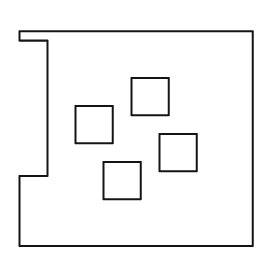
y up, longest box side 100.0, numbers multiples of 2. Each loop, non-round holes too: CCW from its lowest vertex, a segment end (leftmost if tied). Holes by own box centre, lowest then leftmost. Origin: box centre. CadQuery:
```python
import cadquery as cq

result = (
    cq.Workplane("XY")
    .moveTo(-50.0, -46.0)
    .lineTo(50.0, -46.0)
    .lineTo(50.0, 46.0)
    .lineTo(-50.0, 46.0)
    .lineTo(-50.0, 42.0)
    .lineTo(-38.0, 42.0)
    .lineTo(-38.0, -16.0)
    .lineTo(-50.0, -16.0)
    .close()
    .moveTo(-14.0, -26.0)
    .lineTo(2.0, -26.0)
    .lineTo(2.0, -10.0)
    .lineTo(-14.0, -10.0)
    .close()
    .moveTo(10.0, -14.0)
    .lineTo(26.0, -14.0)
    .lineTo(26.0, 2.0)
    .lineTo(10.0, 2.0)
    .close()
    .moveTo(-26.0, -2.0)
    .lineTo(-10.0, -2.0)
    .lineTo(-10.0, 14.0)
    .lineTo(-26.0, 14.0)
    .close()
    .moveTo(-2.0, 10.0)
    .lineTo(14.0, 10.0)
    .lineTo(14.0, 26.0)
    .lineTo(-2.0, 26.0)
    .close()
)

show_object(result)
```